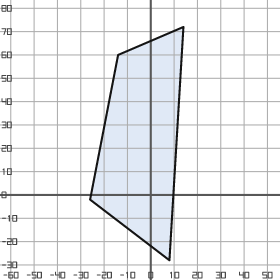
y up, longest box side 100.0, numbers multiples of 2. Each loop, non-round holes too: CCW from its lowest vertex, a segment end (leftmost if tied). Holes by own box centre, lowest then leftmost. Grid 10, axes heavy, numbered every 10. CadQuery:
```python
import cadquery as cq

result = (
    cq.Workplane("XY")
    .moveTo(8.0, -28.0)
    .lineTo(14.0, 72.0)
    .lineTo(-14.0, 60.0)
    .lineTo(-26.0, -2.0)
    .close()
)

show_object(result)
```